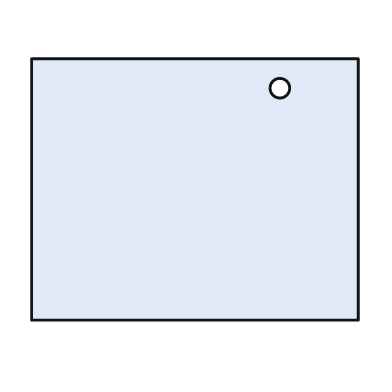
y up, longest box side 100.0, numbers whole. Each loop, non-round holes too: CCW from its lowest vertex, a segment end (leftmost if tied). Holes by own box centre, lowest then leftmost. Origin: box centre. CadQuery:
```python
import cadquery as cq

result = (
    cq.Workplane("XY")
    .moveTo(-50.0, -40.0)
    .lineTo(50.0, -40.0)
    .lineTo(50.0, 40.0)
    .lineTo(-50.0, 40.0)
    .close()
    .moveTo(26.0, 31.0)
    .circle(3.0)
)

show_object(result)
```